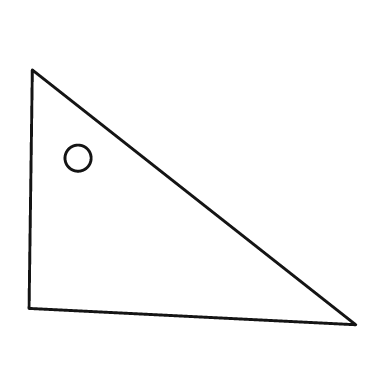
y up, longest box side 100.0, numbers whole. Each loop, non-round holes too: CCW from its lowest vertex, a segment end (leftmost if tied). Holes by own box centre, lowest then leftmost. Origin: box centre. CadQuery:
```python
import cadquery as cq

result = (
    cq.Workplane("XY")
    .moveTo(50.0, -39.0)
    .lineTo(-49.0, 39.0)
    .lineTo(-50.0, -34.0)
    .close()
    .moveTo(-35.0, 12.0)
    .circle(4.0)
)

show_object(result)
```